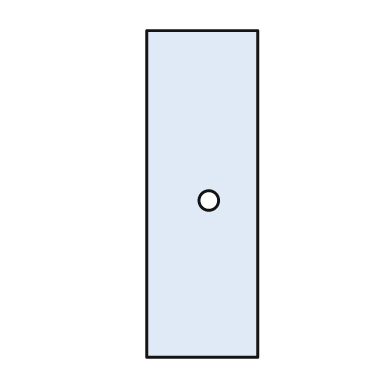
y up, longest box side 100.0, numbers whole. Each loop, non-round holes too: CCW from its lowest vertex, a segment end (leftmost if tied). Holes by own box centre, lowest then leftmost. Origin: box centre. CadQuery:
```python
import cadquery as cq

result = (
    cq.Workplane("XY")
    .moveTo(-17.0, -50.0)
    .lineTo(17.0, -50.0)
    .lineTo(17.0, 50.0)
    .lineTo(-17.0, 50.0)
    .close()
    .moveTo(2.0, -2.0)
    .circle(3.0)
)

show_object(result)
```